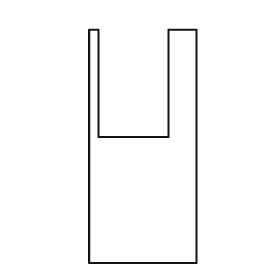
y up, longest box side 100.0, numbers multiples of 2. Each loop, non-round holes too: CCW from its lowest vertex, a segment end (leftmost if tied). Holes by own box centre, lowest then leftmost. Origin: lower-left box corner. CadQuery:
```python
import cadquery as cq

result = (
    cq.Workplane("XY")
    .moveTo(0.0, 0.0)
    .lineTo(46.0, 0.0)
    .lineTo(46.0, 100.0)
    .lineTo(34.0, 100.0)
    .lineTo(34.0, 54.0)
    .lineTo(4.0, 54.0)
    .lineTo(4.0, 100.0)
    .lineTo(0.0, 100.0)
    .close()
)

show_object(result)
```